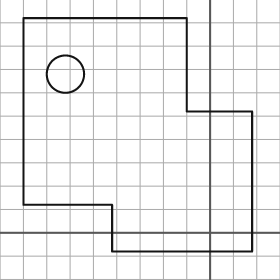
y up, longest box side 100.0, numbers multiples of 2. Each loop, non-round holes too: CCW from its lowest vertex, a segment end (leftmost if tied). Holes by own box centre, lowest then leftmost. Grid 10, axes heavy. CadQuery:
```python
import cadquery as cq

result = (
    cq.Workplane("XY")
    .moveTo(-42.0, -8.0)
    .lineTo(18.0, -8.0)
    .lineTo(18.0, 52.0)
    .lineTo(-10.0, 52.0)
    .lineTo(-10.0, 92.0)
    .lineTo(-80.0, 92.0)
    .lineTo(-80.0, 12.0)
    .lineTo(-42.0, 12.0)
    .close()
    .moveTo(-62.0, 68.0)
    .circle(8.0)
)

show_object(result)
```